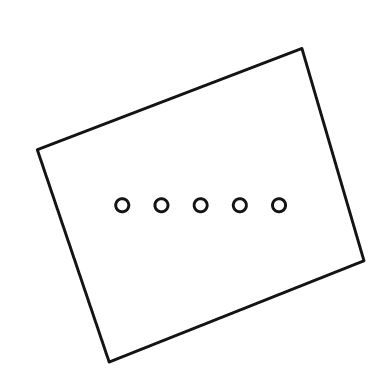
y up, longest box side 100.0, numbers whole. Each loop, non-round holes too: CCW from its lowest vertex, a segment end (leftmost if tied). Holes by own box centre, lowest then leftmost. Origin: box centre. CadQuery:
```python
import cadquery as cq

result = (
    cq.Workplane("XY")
    .moveTo(-28.0, -48.0)
    .lineTo(50.0, -17.0)
    .lineTo(31.0, 48.0)
    .lineTo(-50.0, 17.0)
    .close()
    .moveTo(-24.0, 0.0)
    .circle(2.0)
    .moveTo(-12.0, 0.0)
    .circle(2.0)
    .moveTo(0.0, 0.0)
    .circle(2.0)
    .moveTo(12.0, 0.0)
    .circle(2.0)
    .moveTo(24.0, 0.0)
    .circle(2.0)
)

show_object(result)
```